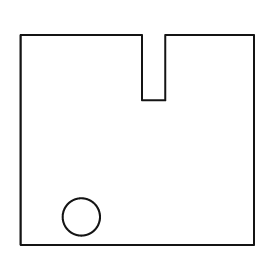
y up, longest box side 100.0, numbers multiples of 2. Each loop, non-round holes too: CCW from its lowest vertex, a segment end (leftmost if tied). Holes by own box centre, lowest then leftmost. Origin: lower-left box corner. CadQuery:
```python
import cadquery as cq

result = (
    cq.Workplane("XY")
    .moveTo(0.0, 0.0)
    .lineTo(100.0, 0.0)
    .lineTo(100.0, 90.0)
    .lineTo(62.0, 90.0)
    .lineTo(62.0, 62.0)
    .lineTo(52.0, 62.0)
    .lineTo(52.0, 90.0)
    .lineTo(0.0, 90.0)
    .close()
    .moveTo(26.0, 12.0)
    .circle(8.0)
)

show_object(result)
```